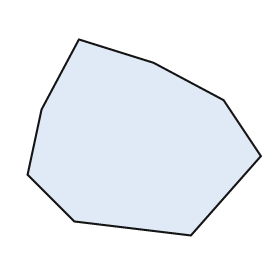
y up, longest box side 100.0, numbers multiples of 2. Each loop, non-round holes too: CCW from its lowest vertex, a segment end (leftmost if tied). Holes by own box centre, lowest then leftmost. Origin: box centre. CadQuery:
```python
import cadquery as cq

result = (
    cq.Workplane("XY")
    .moveTo(20.0, -42.0)
    .lineTo(50.0, -8.0)
    .lineTo(34.0, 16.0)
    .lineTo(4.0, 32.0)
    .lineTo(-28.0, 42.0)
    .lineTo(-44.0, 12.0)
    .lineTo(-50.0, -16.0)
    .lineTo(-30.0, -36.0)
    .close()
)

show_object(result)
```